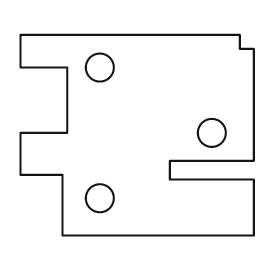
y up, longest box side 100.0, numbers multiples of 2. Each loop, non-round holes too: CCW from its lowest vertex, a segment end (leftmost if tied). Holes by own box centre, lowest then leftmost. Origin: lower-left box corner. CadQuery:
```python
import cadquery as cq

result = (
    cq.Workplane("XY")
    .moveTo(18.0, 0.0)
    .lineTo(100.0, 0.0)
    .lineTo(100.0, 24.0)
    .lineTo(64.0, 24.0)
    .lineTo(64.0, 32.0)
    .lineTo(100.0, 32.0)
    .lineTo(100.0, 80.0)
    .lineTo(94.0, 80.0)
    .lineTo(94.0, 86.0)
    .lineTo(0.0, 86.0)
    .lineTo(0.0, 72.0)
    .lineTo(20.0, 72.0)
    .lineTo(20.0, 44.0)
    .lineTo(0.0, 44.0)
    .lineTo(0.0, 26.0)
    .lineTo(18.0, 26.0)
    .close()
    .moveTo(34.0, 16.0)
    .circle(6.0)
    .moveTo(82.0, 44.0)
    .circle(6.0)
    .moveTo(34.0, 72.0)
    .circle(6.0)
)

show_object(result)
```